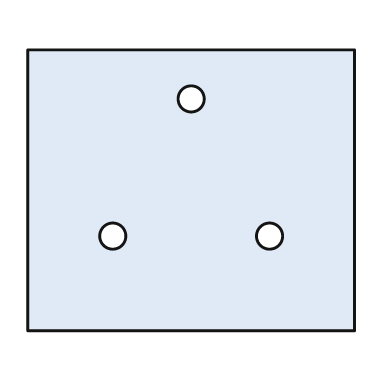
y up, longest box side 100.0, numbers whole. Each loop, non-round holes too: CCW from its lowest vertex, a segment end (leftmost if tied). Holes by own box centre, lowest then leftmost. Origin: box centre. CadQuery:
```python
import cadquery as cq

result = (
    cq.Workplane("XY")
    .moveTo(-50.0, -43.0)
    .lineTo(50.0, -43.0)
    .lineTo(50.0, 43.0)
    .lineTo(-50.0, 43.0)
    .close()
    .moveTo(-24.0, -14.0)
    .circle(4.0)
    .moveTo(24.0, -14.0)
    .circle(4.0)
    .moveTo(0.0, 28.0)
    .circle(4.0)
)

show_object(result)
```